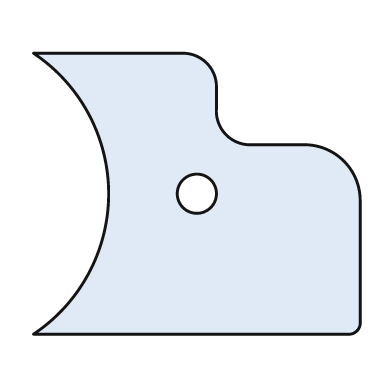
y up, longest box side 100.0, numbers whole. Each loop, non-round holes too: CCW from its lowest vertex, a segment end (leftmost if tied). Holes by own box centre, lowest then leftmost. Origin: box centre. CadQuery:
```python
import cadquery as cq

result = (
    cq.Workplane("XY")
    .moveTo(-50.0, -43.0)
    .lineTo(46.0, -43.0)
    .threePointArc((49.0, -42.0), (50.0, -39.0))
    .lineTo(50.0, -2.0)
    .threePointArc((45.0, 10.0), (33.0, 15.0))
    .lineTo(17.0, 15.0)
    .threePointArc((9.0, 18.0), (6.0, 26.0))
    .lineTo(6.0, 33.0)
    .threePointArc((3.0, 40.0), (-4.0, 43.0))
    .lineTo(-50.0, 43.0)
    .threePointArc((-27.0, 0.0), (-50.0, -43.0))
    .close()
    .moveTo(0.0, 0.0)
    .circle(6.0)
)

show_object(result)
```